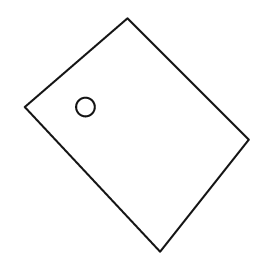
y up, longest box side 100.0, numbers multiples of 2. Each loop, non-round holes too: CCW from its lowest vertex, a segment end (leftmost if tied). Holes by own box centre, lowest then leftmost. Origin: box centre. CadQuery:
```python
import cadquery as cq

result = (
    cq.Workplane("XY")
    .moveTo(10.0, -50.0)
    .lineTo(48.0, -2.0)
    .lineTo(-4.0, 50.0)
    .lineTo(-48.0, 12.0)
    .close()
    .moveTo(-22.0, 12.0)
    .circle(4.0)
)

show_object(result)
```